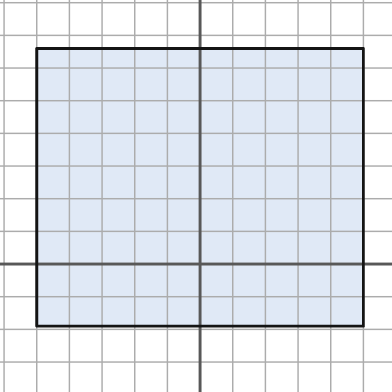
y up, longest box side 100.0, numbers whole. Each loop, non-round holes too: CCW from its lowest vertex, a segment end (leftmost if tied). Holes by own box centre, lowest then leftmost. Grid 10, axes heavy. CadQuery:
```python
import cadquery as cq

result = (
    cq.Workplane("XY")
    .moveTo(-50.0, -19.0)
    .lineTo(50.0, -19.0)
    .lineTo(50.0, 66.0)
    .lineTo(-50.0, 66.0)
    .close()
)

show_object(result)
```